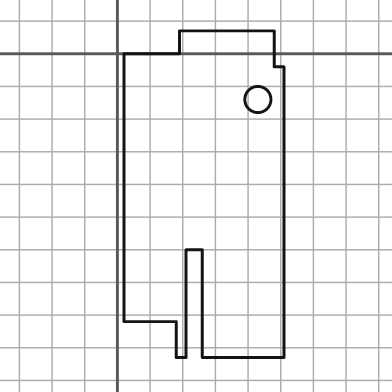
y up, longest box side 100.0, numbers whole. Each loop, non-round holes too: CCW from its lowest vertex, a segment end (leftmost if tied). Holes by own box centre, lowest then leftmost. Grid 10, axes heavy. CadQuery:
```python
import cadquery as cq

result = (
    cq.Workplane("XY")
    .moveTo(18.0, -93.0)
    .lineTo(21.0, -93.0)
    .lineTo(21.0, -60.0)
    .lineTo(26.0, -60.0)
    .lineTo(26.0, -93.0)
    .lineTo(51.0, -93.0)
    .lineTo(51.0, -4.0)
    .lineTo(48.0, -4.0)
    .lineTo(48.0, 7.0)
    .lineTo(19.0, 7.0)
    .lineTo(19.0, 0.0)
    .lineTo(2.0, 0.0)
    .lineTo(2.0, -82.0)
    .lineTo(18.0, -82.0)
    .close()
    .moveTo(43.0, -14.0)
    .circle(4.0)
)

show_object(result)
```